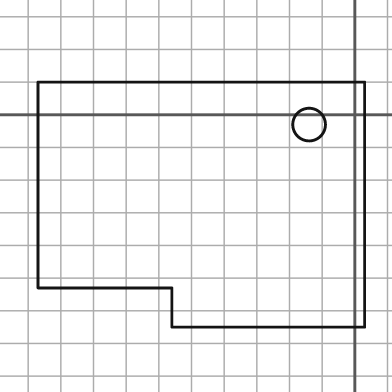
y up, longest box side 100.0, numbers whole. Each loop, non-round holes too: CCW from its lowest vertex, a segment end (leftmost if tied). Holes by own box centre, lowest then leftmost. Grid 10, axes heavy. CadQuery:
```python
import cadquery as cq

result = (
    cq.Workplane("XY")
    .moveTo(-56.0, -65.0)
    .lineTo(3.0, -65.0)
    .lineTo(3.0, 10.0)
    .lineTo(-97.0, 10.0)
    .lineTo(-97.0, -53.0)
    .lineTo(-56.0, -53.0)
    .close()
    .moveTo(-14.0, -3.0)
    .circle(5.0)
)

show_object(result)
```